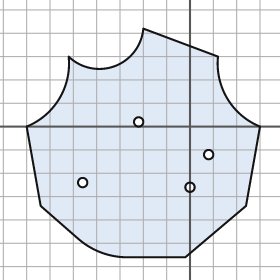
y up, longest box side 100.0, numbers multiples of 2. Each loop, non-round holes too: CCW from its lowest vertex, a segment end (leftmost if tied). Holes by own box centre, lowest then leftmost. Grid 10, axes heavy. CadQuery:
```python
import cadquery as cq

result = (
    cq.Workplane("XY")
    .moveTo(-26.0, -56.0)
    .lineTo(-2.0, -56.0)
    .lineTo(24.0, -34.0)
    .lineTo(30.0, 0.0)
    .threePointArc((16.0, 12.0), (12.0, 30.0))
    .lineTo(-20.0, 42.0)
    .threePointArc((-32.0, 26.0), (-52.0, 30.0))
    .threePointArc((-56.0, 12.0), (-70.0, 0.0))
    .lineTo(-64.0, -34.0)
    .lineTo(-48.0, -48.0)
    .threePointArc((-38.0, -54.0), (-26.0, -56.0))
    .close()
    .moveTo(0.0, -26.0)
    .circle(2.0)
    .moveTo(-46.0, -24.0)
    .circle(2.0)
    .moveTo(8.0, -12.0)
    .circle(2.0)
    .moveTo(-22.0, 2.0)
    .circle(2.0)
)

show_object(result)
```